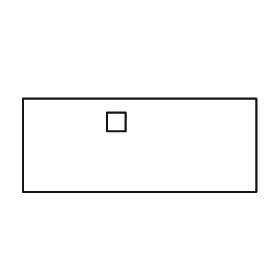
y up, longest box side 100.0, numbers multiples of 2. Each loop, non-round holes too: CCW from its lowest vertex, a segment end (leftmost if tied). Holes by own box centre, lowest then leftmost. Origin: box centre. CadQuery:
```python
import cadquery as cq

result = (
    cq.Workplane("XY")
    .moveTo(-50.0, -20.0)
    .lineTo(50.0, -20.0)
    .lineTo(50.0, 20.0)
    .lineTo(-50.0, 20.0)
    .close()
    .moveTo(-14.0, 6.0)
    .lineTo(-6.0, 6.0)
    .lineTo(-6.0, 14.0)
    .lineTo(-14.0, 14.0)
    .close()
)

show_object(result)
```